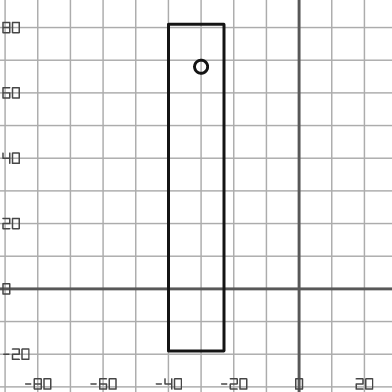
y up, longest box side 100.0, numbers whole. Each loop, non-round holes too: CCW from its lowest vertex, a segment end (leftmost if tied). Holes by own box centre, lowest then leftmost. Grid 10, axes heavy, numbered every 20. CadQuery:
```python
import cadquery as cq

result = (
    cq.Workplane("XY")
    .moveTo(-40.0, -19.0)
    .lineTo(-23.0, -19.0)
    .lineTo(-23.0, 81.0)
    .lineTo(-40.0, 81.0)
    .close()
    .moveTo(-30.0, 68.0)
    .circle(2.0)
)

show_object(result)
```